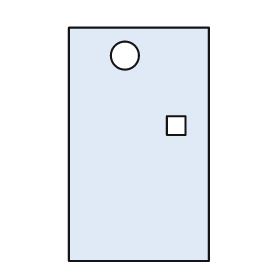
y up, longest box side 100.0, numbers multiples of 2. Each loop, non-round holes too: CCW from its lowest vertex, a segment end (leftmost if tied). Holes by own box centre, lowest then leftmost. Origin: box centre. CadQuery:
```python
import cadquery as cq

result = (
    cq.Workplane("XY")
    .moveTo(-30.0, -50.0)
    .lineTo(30.0, -50.0)
    .lineTo(30.0, 50.0)
    .lineTo(-30.0, 50.0)
    .close()
    .moveTo(12.0, 4.0)
    .lineTo(20.0, 4.0)
    .lineTo(20.0, 12.0)
    .lineTo(12.0, 12.0)
    .close()
    .moveTo(-6.0, 38.0)
    .circle(6.0)
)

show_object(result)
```